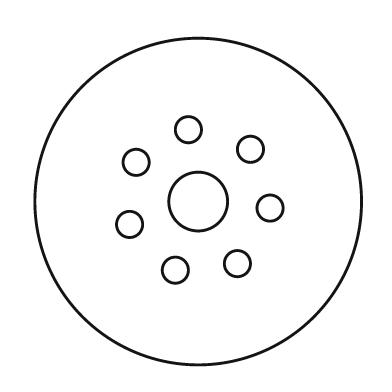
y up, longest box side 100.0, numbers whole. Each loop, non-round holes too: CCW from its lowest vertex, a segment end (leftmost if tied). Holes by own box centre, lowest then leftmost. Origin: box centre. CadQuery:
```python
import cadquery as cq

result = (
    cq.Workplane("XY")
    .moveTo(0.0, 0.0)
    .circle(50.0)
    .moveTo(-7.0, -21.0)
    .circle(4.0)
    .moveTo(12.0, -19.0)
    .circle(4.0)
    .moveTo(-21.0, -7.0)
    .circle(4.0)
    .moveTo(22.0, -2.0)
    .circle(4.0)
    .moveTo(0.0, 0.0)
    .circle(9.0)
    .moveTo(-19.0, 12.0)
    .circle(4.0)
    .moveTo(16.0, 16.0)
    .circle(4.0)
    .moveTo(-3.0, 22.0)
    .circle(4.0)
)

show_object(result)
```